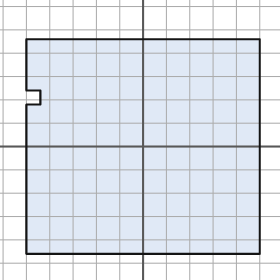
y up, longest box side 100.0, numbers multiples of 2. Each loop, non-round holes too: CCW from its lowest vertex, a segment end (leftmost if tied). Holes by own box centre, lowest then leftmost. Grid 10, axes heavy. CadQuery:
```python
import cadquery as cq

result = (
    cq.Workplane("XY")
    .moveTo(-50.0, -46.0)
    .lineTo(50.0, -46.0)
    .lineTo(50.0, 46.0)
    .lineTo(-50.0, 46.0)
    .lineTo(-50.0, 24.0)
    .lineTo(-44.0, 24.0)
    .lineTo(-44.0, 18.0)
    .lineTo(-50.0, 18.0)
    .close()
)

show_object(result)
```